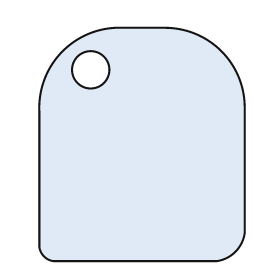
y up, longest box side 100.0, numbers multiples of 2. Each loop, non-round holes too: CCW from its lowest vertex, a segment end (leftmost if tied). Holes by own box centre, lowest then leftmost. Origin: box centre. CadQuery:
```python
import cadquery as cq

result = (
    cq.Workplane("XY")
    .moveTo(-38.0, -50.0)
    .lineTo(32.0, -50.0)
    .threePointArc((40.0, -46.0), (44.0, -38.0))
    .lineTo(44.0, 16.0)
    .threePointArc((34.0, 40.0), (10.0, 50.0))
    .lineTo(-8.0, 50.0)
    .threePointArc((-34.0, 40.0), (-44.0, 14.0))
    .lineTo(-44.0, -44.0)
    .threePointArc((-42.0, -48.0), (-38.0, -50.0))
    .close()
    .moveTo(-22.0, 32.0)
    .circle(8.0)
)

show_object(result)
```